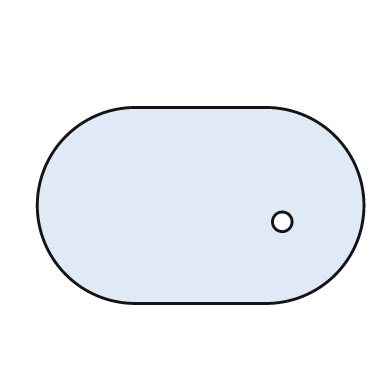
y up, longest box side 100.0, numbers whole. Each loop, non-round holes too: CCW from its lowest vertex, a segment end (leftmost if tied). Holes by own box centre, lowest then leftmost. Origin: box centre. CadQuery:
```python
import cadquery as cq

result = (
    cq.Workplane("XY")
    .moveTo(-20.0, -30.0)
    .lineTo(20.0, -30.0)
    .threePointArc((50.0, 0.0), (20.0, 30.0))
    .lineTo(-20.0, 30.0)
    .threePointArc((-50.0, 0.0), (-20.0, -30.0))
    .close()
    .moveTo(25.0, -5.0)
    .circle(3.0)
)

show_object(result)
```